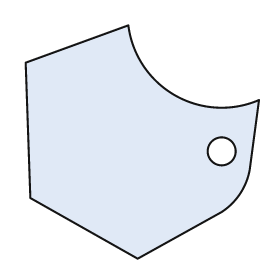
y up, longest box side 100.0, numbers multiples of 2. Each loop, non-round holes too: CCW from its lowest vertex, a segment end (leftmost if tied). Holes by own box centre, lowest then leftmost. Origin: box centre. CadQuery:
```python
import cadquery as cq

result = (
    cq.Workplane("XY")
    .moveTo(-2.0, -50.0)
    .lineTo(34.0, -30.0)
    .threePointArc((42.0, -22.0), (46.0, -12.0))
    .lineTo(50.0, 18.0)
    .threePointArc((14.0, 20.0), (-6.0, 50.0))
    .lineTo(-50.0, 34.0)
    .lineTo(-48.0, -24.0)
    .close()
    .moveTo(34.0, -4.0)
    .circle(6.0)
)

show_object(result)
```